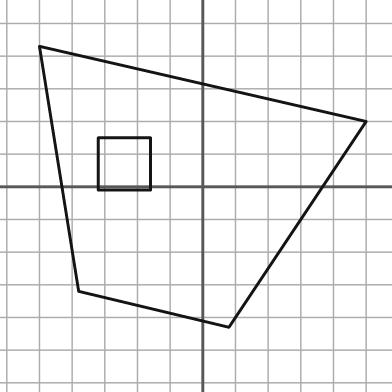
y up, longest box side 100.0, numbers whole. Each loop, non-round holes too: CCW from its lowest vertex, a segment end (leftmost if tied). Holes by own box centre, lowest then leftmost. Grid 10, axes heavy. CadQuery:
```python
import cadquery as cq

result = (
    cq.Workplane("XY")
    .moveTo(8.0, -43.0)
    .lineTo(50.0, 20.0)
    .lineTo(-50.0, 43.0)
    .lineTo(-38.0, -32.0)
    .close()
    .moveTo(-32.0, -1.0)
    .lineTo(-16.0, -1.0)
    .lineTo(-16.0, 15.0)
    .lineTo(-32.0, 15.0)
    .close()
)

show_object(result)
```